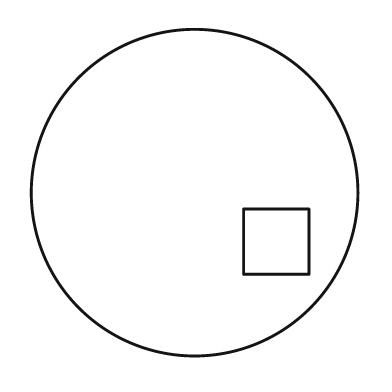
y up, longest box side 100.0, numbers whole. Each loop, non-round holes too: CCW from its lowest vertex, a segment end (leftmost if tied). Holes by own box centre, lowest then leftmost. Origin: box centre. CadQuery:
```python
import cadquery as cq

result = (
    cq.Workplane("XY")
    .moveTo(0.0, 0.0)
    .circle(50.0)
    .moveTo(15.0, -25.0)
    .lineTo(35.0, -25.0)
    .lineTo(35.0, -5.0)
    .lineTo(15.0, -5.0)
    .close()
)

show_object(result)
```